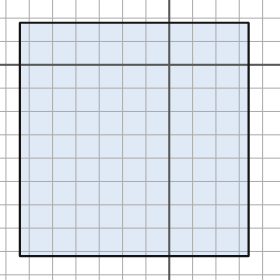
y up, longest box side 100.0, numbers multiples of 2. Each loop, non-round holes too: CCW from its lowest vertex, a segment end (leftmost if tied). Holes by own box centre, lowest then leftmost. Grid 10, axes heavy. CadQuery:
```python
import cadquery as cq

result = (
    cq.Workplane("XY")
    .moveTo(-64.0, -82.0)
    .lineTo(34.0, -82.0)
    .lineTo(34.0, 18.0)
    .lineTo(-64.0, 18.0)
    .close()
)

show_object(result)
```